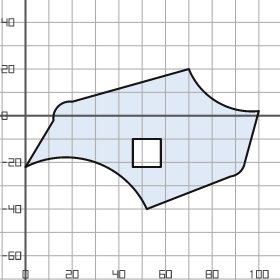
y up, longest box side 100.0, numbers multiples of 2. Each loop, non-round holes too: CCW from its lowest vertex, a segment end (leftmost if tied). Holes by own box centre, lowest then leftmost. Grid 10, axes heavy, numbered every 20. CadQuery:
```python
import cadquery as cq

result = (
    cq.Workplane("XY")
    .moveTo(52.0, -40.0)
    .lineTo(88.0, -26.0)
    .threePointArc((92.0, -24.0), (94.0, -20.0))
    .lineTo(100.0, 2.0)
    .threePointArc((82.0, 6.0), (70.0, 20.0))
    .lineTo(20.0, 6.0)
    .threePointArc((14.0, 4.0), (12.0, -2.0))
    .lineTo(0.0, -22.0)
    .threePointArc((30.0, -20.0), (52.0, -40.0))
    .close()
    .moveTo(46.0, -22.0)
    .lineTo(58.0, -22.0)
    .lineTo(58.0, -10.0)
    .lineTo(46.0, -10.0)
    .close()
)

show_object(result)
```